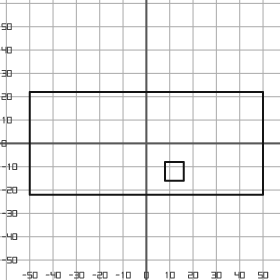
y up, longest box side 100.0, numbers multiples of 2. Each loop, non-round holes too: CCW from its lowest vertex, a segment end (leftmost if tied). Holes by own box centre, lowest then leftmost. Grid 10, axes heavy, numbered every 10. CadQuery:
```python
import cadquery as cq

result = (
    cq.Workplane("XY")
    .moveTo(-50.0, -22.0)
    .lineTo(50.0, -22.0)
    .lineTo(50.0, 22.0)
    .lineTo(-50.0, 22.0)
    .close()
    .moveTo(8.0, -16.0)
    .lineTo(16.0, -16.0)
    .lineTo(16.0, -8.0)
    .lineTo(8.0, -8.0)
    .close()
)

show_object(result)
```